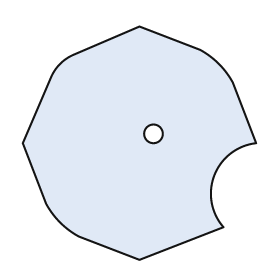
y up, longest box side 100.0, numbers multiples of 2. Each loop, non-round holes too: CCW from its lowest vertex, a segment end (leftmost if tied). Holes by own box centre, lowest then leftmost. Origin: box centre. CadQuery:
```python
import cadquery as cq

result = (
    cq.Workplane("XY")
    .moveTo(0.0, -50.0)
    .lineTo(36.0, -36.0)
    .threePointArc((32.0, -14.0), (50.0, 0.0))
    .lineTo(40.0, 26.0)
    .threePointArc((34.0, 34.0), (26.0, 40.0))
    .lineTo(0.0, 50.0)
    .lineTo(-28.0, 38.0)
    .threePointArc((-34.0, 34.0), (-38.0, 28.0))
    .lineTo(-50.0, 0.0)
    .lineTo(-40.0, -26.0)
    .threePointArc((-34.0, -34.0), (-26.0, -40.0))
    .close()
    .moveTo(6.0, 4.0)
    .circle(4.0)
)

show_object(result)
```